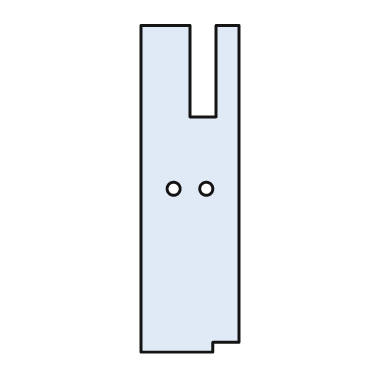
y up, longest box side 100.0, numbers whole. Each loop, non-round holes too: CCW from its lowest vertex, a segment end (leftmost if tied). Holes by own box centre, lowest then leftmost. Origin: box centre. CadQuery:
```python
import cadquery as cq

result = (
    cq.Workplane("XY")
    .moveTo(-15.0, -50.0)
    .lineTo(7.0, -50.0)
    .lineTo(7.0, -47.0)
    .lineTo(15.0, -47.0)
    .lineTo(15.0, 50.0)
    .lineTo(8.0, 50.0)
    .lineTo(8.0, 22.0)
    .lineTo(0.0, 22.0)
    .lineTo(0.0, 50.0)
    .lineTo(-15.0, 50.0)
    .close()
    .moveTo(-5.0, 0.0)
    .circle(2.0)
    .moveTo(5.0, 0.0)
    .circle(2.0)
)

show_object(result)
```